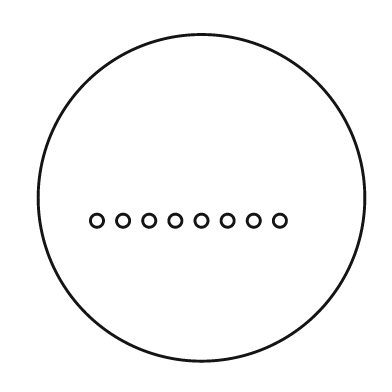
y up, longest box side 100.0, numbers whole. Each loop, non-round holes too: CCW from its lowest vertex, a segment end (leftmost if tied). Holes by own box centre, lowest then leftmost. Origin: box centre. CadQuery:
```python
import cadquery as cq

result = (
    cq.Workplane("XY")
    .moveTo(0.0, 0.0)
    .circle(50.0)
    .moveTo(-32.0, -7.0)
    .circle(2.0)
    .moveTo(-24.0, -7.0)
    .circle(2.0)
    .moveTo(-16.0, -7.0)
    .circle(2.0)
    .moveTo(-8.0, -7.0)
    .circle(2.0)
    .moveTo(0.0, -7.0)
    .circle(2.0)
    .moveTo(8.0, -7.0)
    .circle(2.0)
    .moveTo(16.0, -7.0)
    .circle(2.0)
    .moveTo(24.0, -7.0)
    .circle(2.0)
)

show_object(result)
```